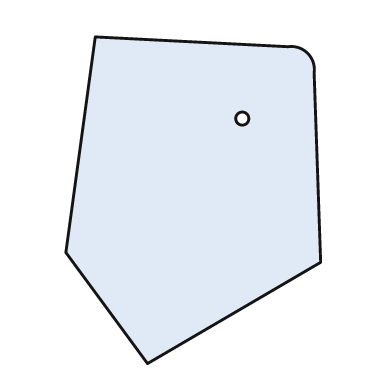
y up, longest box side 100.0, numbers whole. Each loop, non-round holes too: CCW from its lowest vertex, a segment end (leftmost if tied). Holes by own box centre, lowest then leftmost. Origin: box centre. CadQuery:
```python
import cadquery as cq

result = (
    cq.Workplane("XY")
    .moveTo(-14.0, -50.0)
    .lineTo(39.0, -19.0)
    .lineTo(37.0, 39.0)
    .threePointArc((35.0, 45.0), (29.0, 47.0))
    .lineTo(-30.0, 50.0)
    .lineTo(-39.0, -16.0)
    .close()
    .moveTo(15.0, 25.0)
    .circle(2.0)
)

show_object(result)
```